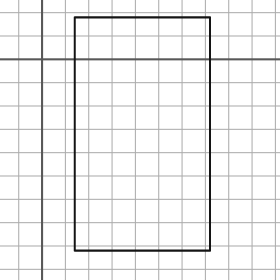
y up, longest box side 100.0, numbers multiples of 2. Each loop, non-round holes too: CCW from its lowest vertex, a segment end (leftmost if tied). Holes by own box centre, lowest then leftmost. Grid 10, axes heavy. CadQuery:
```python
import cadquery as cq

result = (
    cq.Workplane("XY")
    .moveTo(14.0, -82.0)
    .lineTo(72.0, -82.0)
    .lineTo(72.0, 18.0)
    .lineTo(14.0, 18.0)
    .close()
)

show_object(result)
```